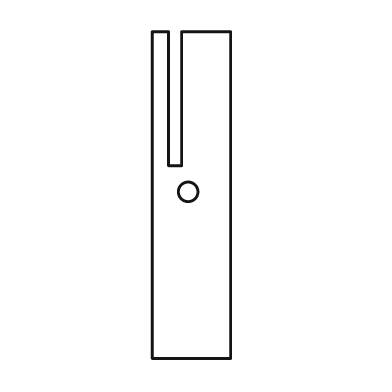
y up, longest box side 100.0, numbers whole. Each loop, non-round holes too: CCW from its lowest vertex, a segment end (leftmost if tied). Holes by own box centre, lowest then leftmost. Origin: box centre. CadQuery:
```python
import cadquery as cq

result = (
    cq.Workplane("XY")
    .moveTo(-12.0, -50.0)
    .lineTo(12.0, -50.0)
    .lineTo(12.0, 50.0)
    .lineTo(-3.0, 50.0)
    .lineTo(-3.0, 9.0)
    .lineTo(-7.0, 9.0)
    .lineTo(-7.0, 50.0)
    .lineTo(-12.0, 50.0)
    .close()
    .moveTo(-1.0, 1.0)
    .circle(3.0)
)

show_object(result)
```